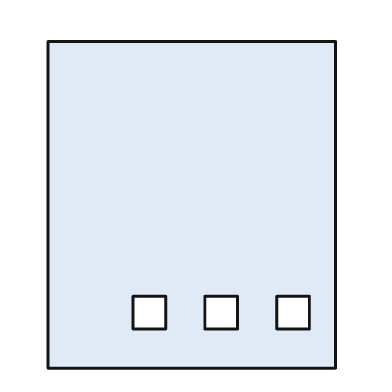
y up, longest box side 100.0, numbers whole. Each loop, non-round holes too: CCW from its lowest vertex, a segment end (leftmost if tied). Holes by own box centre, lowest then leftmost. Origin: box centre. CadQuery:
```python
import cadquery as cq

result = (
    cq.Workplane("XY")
    .moveTo(-44.0, -50.0)
    .lineTo(44.0, -50.0)
    .lineTo(44.0, 50.0)
    .lineTo(-44.0, 50.0)
    .close()
    .moveTo(-18.0, -38.0)
    .lineTo(-8.0, -38.0)
    .lineTo(-8.0, -28.0)
    .lineTo(-18.0, -28.0)
    .close()
    .moveTo(4.0, -38.0)
    .lineTo(14.0, -38.0)
    .lineTo(14.0, -28.0)
    .lineTo(4.0, -28.0)
    .close()
    .moveTo(26.0, -38.0)
    .lineTo(36.0, -38.0)
    .lineTo(36.0, -28.0)
    .lineTo(26.0, -28.0)
    .close()
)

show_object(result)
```